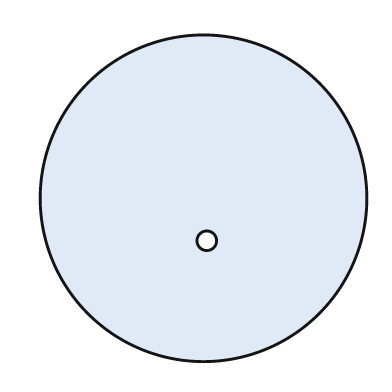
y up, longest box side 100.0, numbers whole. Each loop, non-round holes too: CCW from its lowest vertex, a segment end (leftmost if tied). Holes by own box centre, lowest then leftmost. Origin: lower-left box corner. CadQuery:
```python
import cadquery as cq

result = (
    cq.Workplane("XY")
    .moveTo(50.0, 50.0)
    .circle(50.0)
    .moveTo(51.0, 37.0)
    .circle(3.0)
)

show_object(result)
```